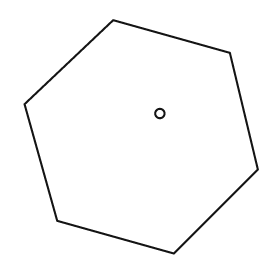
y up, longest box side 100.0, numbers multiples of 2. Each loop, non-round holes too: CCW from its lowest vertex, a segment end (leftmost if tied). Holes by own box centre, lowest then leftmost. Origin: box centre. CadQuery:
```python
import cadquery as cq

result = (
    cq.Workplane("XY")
    .moveTo(14.0, -50.0)
    .lineTo(50.0, -14.0)
    .lineTo(38.0, 36.0)
    .lineTo(-12.0, 50.0)
    .lineTo(-50.0, 14.0)
    .lineTo(-36.0, -36.0)
    .close()
    .moveTo(8.0, 10.0)
    .circle(2.0)
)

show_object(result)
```